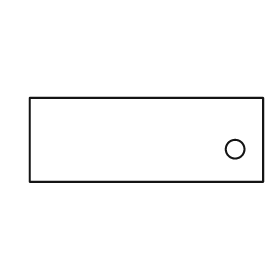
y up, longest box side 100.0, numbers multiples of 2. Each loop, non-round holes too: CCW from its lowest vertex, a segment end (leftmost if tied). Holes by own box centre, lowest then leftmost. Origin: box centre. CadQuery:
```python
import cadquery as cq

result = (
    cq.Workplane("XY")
    .moveTo(-50.0, -18.0)
    .lineTo(50.0, -18.0)
    .lineTo(50.0, 18.0)
    .lineTo(-50.0, 18.0)
    .close()
    .moveTo(38.0, -4.0)
    .circle(4.0)
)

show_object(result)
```